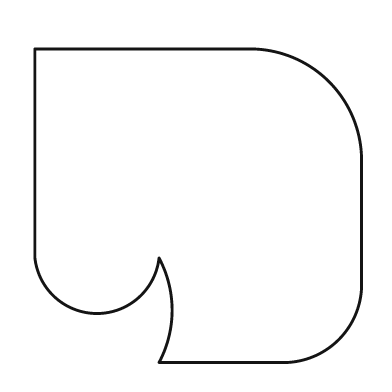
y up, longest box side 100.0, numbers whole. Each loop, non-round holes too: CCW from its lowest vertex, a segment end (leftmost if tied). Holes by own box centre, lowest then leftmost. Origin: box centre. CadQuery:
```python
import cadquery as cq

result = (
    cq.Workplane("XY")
    .moveTo(-12.0, -48.0)
    .lineTo(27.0, -48.0)
    .threePointArc((43.0, -41.0), (50.0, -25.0))
    .lineTo(50.0, 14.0)
    .threePointArc((40.0, 38.0), (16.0, 48.0))
    .lineTo(-50.0, 48.0)
    .lineTo(-50.0, -16.0)
    .threePointArc((-31.0, -33.0), (-12.0, -16.0))
    .threePointArc((-8.0, -32.0), (-12.0, -48.0))
    .close()
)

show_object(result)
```